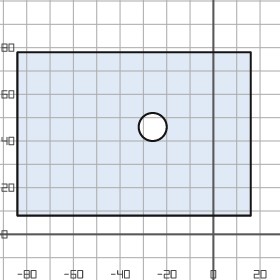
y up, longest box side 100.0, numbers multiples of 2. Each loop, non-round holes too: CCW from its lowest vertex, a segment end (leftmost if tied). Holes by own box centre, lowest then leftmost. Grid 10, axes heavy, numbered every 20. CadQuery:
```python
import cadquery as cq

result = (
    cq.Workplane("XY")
    .moveTo(-84.0, 8.0)
    .lineTo(16.0, 8.0)
    .lineTo(16.0, 78.0)
    .lineTo(-84.0, 78.0)
    .close()
    .moveTo(-26.0, 46.0)
    .circle(6.0)
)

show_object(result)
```